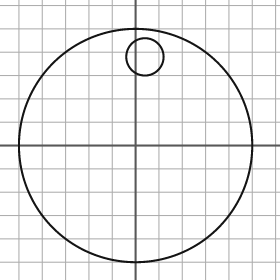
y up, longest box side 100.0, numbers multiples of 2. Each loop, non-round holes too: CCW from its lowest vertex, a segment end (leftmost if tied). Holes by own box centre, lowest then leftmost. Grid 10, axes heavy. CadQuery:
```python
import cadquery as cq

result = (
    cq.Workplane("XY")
    .moveTo(0.0, 0.0)
    .circle(50.0)
    .moveTo(4.0, 38.0)
    .circle(8.0)
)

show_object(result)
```